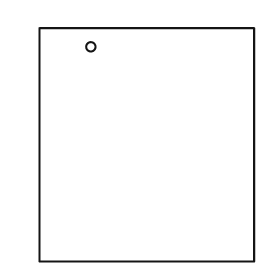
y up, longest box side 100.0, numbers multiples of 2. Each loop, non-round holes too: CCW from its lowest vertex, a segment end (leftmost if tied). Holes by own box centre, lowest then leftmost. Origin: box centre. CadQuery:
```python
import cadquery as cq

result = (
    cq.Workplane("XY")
    .moveTo(-46.0, -50.0)
    .lineTo(46.0, -50.0)
    .lineTo(46.0, 50.0)
    .lineTo(-46.0, 50.0)
    .close()
    .moveTo(-24.0, 42.0)
    .circle(2.0)
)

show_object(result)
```